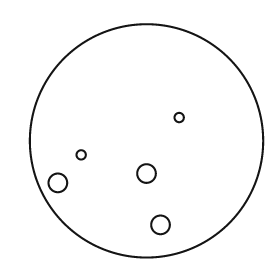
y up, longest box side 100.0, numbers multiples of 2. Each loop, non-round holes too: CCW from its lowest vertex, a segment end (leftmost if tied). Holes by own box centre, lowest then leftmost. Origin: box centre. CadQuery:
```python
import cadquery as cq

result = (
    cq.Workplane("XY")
    .moveTo(0.0, 0.0)
    .circle(50.0)
    .moveTo(6.0, -36.0)
    .circle(4.0)
    .moveTo(-38.0, -18.0)
    .circle(4.0)
    .moveTo(0.0, -14.0)
    .circle(4.0)
    .moveTo(-28.0, -6.0)
    .circle(2.0)
    .moveTo(14.0, 10.0)
    .circle(2.0)
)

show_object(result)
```